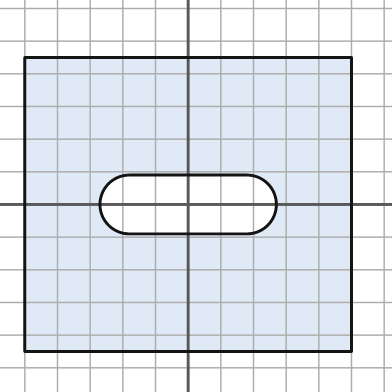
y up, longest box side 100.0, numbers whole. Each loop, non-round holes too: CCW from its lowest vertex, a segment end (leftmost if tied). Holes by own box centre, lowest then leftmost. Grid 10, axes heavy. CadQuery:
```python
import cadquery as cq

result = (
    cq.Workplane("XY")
    .moveTo(-50.0, -45.0)
    .lineTo(50.0, -45.0)
    .lineTo(50.0, 45.0)
    .lineTo(-50.0, 45.0)
    .close()
    .moveTo(-18.0, -9.0)
    .lineTo(18.0, -9.0)
    .threePointArc((27.0, 0.0), (18.0, 9.0))
    .lineTo(-18.0, 9.0)
    .threePointArc((-27.0, 0.0), (-18.0, -9.0))
    .close()
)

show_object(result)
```